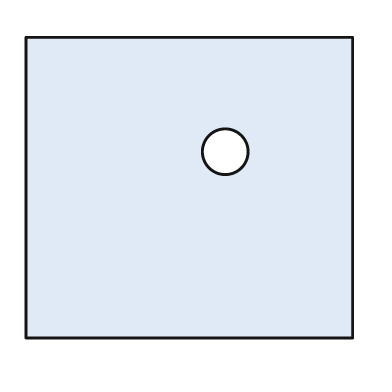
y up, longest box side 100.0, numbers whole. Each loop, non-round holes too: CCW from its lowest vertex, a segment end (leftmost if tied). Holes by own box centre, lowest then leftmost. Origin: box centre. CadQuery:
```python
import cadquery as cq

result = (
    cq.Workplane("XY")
    .moveTo(-50.0, -46.0)
    .lineTo(50.0, -46.0)
    .lineTo(50.0, 46.0)
    .lineTo(-50.0, 46.0)
    .close()
    .moveTo(11.0, 11.0)
    .circle(7.0)
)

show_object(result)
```